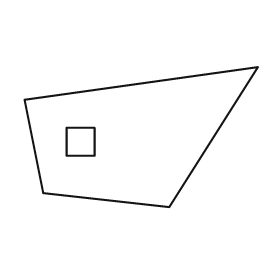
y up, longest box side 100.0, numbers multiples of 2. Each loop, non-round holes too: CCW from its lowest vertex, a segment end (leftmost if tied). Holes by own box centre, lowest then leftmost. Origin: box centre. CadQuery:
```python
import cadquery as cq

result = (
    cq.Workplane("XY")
    .moveTo(12.0, -30.0)
    .lineTo(50.0, 30.0)
    .lineTo(-50.0, 16.0)
    .lineTo(-42.0, -24.0)
    .close()
    .moveTo(-32.0, -8.0)
    .lineTo(-20.0, -8.0)
    .lineTo(-20.0, 4.0)
    .lineTo(-32.0, 4.0)
    .close()
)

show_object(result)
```